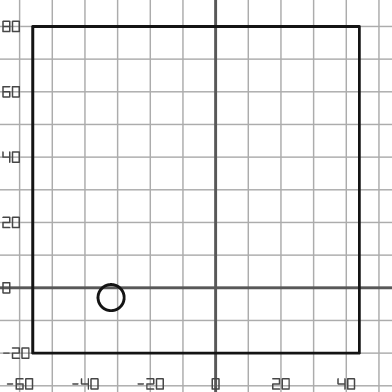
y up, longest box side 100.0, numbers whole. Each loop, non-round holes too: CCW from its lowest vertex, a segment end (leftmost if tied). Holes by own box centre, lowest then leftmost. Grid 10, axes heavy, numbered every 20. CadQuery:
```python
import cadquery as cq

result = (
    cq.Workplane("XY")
    .moveTo(-56.0, -20.0)
    .lineTo(44.0, -20.0)
    .lineTo(44.0, 80.0)
    .lineTo(-56.0, 80.0)
    .close()
    .moveTo(-32.0, -3.0)
    .circle(4.0)
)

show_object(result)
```